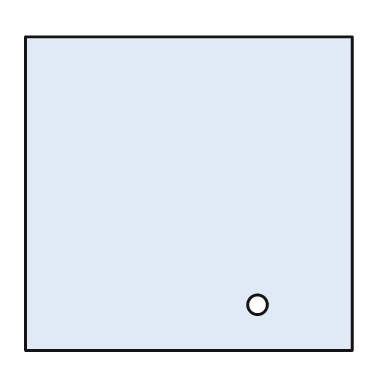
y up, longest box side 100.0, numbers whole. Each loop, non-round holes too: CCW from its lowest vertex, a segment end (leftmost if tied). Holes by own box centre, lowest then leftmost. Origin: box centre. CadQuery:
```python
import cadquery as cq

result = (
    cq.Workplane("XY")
    .moveTo(-50.0, -48.0)
    .lineTo(50.0, -48.0)
    .lineTo(50.0, 48.0)
    .lineTo(-50.0, 48.0)
    .close()
    .moveTo(21.0, -34.0)
    .circle(3.0)
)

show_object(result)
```